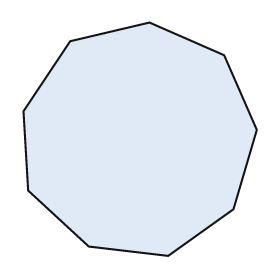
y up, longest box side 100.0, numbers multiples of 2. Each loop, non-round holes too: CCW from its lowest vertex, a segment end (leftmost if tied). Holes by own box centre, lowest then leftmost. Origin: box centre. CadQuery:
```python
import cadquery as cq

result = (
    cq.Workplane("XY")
    .moveTo(12.0, -50.0)
    .lineTo(40.0, -30.0)
    .lineTo(50.0, 4.0)
    .lineTo(36.0, 36.0)
    .lineTo(4.0, 50.0)
    .lineTo(-30.0, 42.0)
    .lineTo(-50.0, 12.0)
    .lineTo(-48.0, -22.0)
    .lineTo(-22.0, -46.0)
    .close()
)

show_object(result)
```